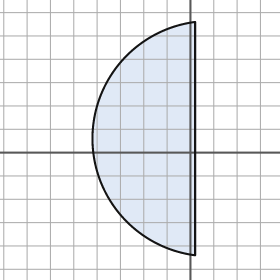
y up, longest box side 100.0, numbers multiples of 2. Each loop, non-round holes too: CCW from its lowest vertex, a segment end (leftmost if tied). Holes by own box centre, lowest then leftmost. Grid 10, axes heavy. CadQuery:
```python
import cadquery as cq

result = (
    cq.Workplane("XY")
    .moveTo(2.0, -44.0)
    .lineTo(2.0, 56.0)
    .threePointArc((-42.0, 6.0), (2.0, -44.0))
    .close()
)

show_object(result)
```